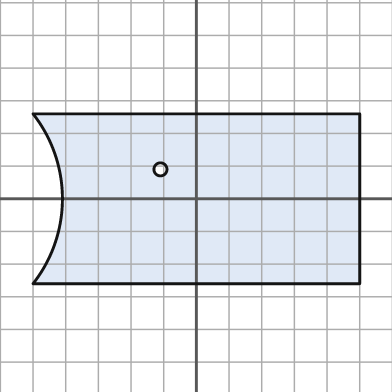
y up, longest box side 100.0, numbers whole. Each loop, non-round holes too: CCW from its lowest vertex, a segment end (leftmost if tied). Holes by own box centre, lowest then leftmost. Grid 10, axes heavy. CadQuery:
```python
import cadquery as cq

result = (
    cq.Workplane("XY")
    .moveTo(-50.0, -26.0)
    .lineTo(50.0, -26.0)
    .lineTo(50.0, 26.0)
    .lineTo(-50.0, 26.0)
    .threePointArc((-41.0, 0.0), (-50.0, -26.0))
    .close()
    .moveTo(-11.0, 9.0)
    .circle(2.0)
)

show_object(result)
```